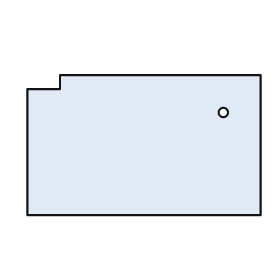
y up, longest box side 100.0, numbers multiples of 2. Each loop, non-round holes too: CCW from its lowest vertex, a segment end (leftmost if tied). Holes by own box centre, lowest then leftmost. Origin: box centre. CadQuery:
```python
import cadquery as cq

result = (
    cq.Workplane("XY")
    .moveTo(-50.0, -30.0)
    .lineTo(50.0, -30.0)
    .lineTo(50.0, 30.0)
    .lineTo(-36.0, 30.0)
    .lineTo(-36.0, 24.0)
    .lineTo(-50.0, 24.0)
    .close()
    .moveTo(34.0, 14.0)
    .circle(2.0)
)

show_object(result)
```